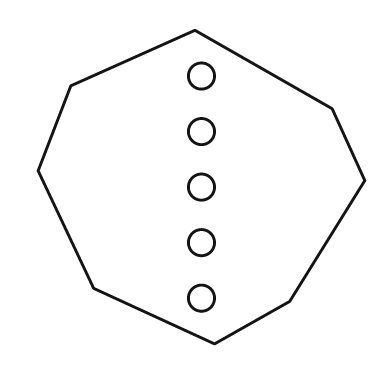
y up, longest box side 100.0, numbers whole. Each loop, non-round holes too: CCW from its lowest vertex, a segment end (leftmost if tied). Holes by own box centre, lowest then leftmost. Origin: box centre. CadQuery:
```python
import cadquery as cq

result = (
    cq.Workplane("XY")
    .moveTo(4.0, -48.0)
    .lineTo(27.0, -35.0)
    .lineTo(50.0, 2.0)
    .lineTo(40.0, 24.0)
    .lineTo(-2.0, 48.0)
    .lineTo(-40.0, 31.0)
    .lineTo(-50.0, 5.0)
    .lineTo(-33.0, -31.0)
    .close()
    .moveTo(0.0, -34.0)
    .circle(4.0)
    .moveTo(0.0, -17.0)
    .circle(4.0)
    .moveTo(0.0, 0.0)
    .circle(4.0)
    .moveTo(0.0, 17.0)
    .circle(4.0)
    .moveTo(0.0, 34.0)
    .circle(4.0)
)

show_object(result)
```